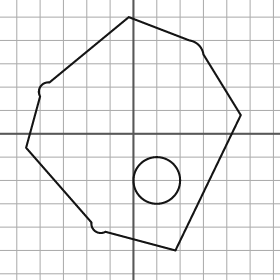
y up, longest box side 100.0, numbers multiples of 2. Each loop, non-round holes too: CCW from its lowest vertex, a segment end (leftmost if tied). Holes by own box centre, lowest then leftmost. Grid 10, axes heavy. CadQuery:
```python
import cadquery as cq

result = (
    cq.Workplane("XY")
    .moveTo(18.0, -50.0)
    .lineTo(46.0, 8.0)
    .lineTo(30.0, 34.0)
    .threePointArc((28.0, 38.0), (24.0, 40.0))
    .lineTo(-2.0, 50.0)
    .lineTo(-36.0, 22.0)
    .threePointArc((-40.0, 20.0), (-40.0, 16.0))
    .lineTo(-46.0, -6.0)
    .lineTo(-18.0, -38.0)
    .threePointArc((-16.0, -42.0), (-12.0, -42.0))
    .close()
    .moveTo(10.0, -20.0)
    .circle(10.0)
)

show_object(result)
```